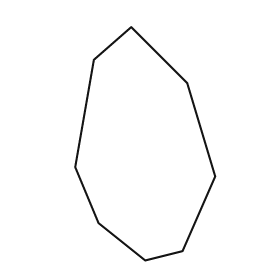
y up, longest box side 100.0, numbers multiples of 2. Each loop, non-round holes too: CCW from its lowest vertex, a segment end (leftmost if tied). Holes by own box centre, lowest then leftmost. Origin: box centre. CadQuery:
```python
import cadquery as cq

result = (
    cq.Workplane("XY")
    .moveTo(0.0, -50.0)
    .lineTo(16.0, -46.0)
    .lineTo(30.0, -14.0)
    .lineTo(18.0, 26.0)
    .lineTo(-6.0, 50.0)
    .lineTo(-22.0, 36.0)
    .lineTo(-30.0, -10.0)
    .lineTo(-20.0, -34.0)
    .close()
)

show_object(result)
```